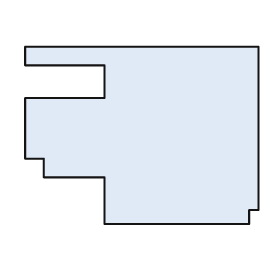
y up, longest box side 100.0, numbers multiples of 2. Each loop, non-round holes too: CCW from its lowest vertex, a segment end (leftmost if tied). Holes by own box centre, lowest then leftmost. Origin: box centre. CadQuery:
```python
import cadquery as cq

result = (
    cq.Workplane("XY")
    .moveTo(-16.0, -38.0)
    .lineTo(46.0, -38.0)
    .lineTo(46.0, -32.0)
    .lineTo(50.0, -32.0)
    .lineTo(50.0, 38.0)
    .lineTo(-50.0, 38.0)
    .lineTo(-50.0, 30.0)
    .lineTo(-16.0, 30.0)
    .lineTo(-16.0, 16.0)
    .lineTo(-50.0, 16.0)
    .lineTo(-50.0, -10.0)
    .lineTo(-42.0, -10.0)
    .lineTo(-42.0, -18.0)
    .lineTo(-16.0, -18.0)
    .close()
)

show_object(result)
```